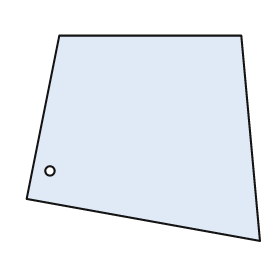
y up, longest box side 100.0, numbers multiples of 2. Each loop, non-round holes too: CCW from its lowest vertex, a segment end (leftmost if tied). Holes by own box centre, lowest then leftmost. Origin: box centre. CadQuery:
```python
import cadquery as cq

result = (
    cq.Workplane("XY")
    .moveTo(50.0, -44.0)
    .lineTo(42.0, 44.0)
    .lineTo(-36.0, 44.0)
    .lineTo(-50.0, -26.0)
    .close()
    .moveTo(-40.0, -14.0)
    .circle(2.0)
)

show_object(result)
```